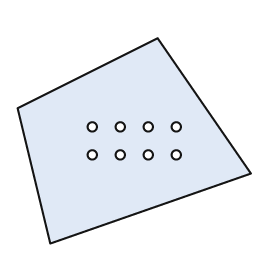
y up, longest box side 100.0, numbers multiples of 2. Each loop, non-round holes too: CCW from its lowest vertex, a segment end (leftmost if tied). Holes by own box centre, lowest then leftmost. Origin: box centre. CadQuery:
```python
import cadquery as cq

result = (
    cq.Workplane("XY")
    .moveTo(-36.0, -44.0)
    .lineTo(50.0, -14.0)
    .lineTo(10.0, 44.0)
    .lineTo(-50.0, 14.0)
    .close()
    .moveTo(-18.0, -6.0)
    .circle(2.0)
    .moveTo(-6.0, -6.0)
    .circle(2.0)
    .moveTo(6.0, -6.0)
    .circle(2.0)
    .moveTo(18.0, -6.0)
    .circle(2.0)
    .moveTo(-18.0, 6.0)
    .circle(2.0)
    .moveTo(-6.0, 6.0)
    .circle(2.0)
    .moveTo(6.0, 6.0)
    .circle(2.0)
    .moveTo(18.0, 6.0)
    .circle(2.0)
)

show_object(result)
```